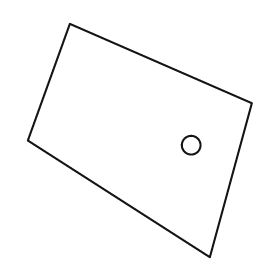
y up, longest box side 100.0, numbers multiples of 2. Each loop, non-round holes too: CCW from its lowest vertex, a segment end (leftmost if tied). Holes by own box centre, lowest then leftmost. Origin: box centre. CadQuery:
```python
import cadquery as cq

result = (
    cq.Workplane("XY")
    .moveTo(30.0, -50.0)
    .lineTo(48.0, 16.0)
    .lineTo(-30.0, 50.0)
    .lineTo(-48.0, 0.0)
    .close()
    .moveTo(22.0, -2.0)
    .circle(4.0)
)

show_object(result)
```